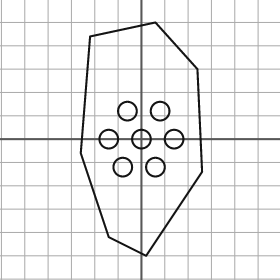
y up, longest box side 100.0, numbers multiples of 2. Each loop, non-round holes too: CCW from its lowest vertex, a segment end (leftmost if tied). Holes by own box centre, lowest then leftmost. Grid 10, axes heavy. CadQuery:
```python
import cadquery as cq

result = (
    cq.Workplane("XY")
    .moveTo(2.0, -50.0)
    .lineTo(26.0, -14.0)
    .lineTo(24.0, 30.0)
    .lineTo(6.0, 50.0)
    .lineTo(-22.0, 44.0)
    .lineTo(-26.0, -6.0)
    .lineTo(-14.0, -42.0)
    .close()
    .moveTo(-8.0, -12.0)
    .circle(4.0)
    .moveTo(6.0, -12.0)
    .circle(4.0)
    .moveTo(-14.0, 0.0)
    .circle(4.0)
    .moveTo(0.0, 0.0)
    .circle(4.0)
    .moveTo(14.0, 0.0)
    .circle(4.0)
    .moveTo(-6.0, 12.0)
    .circle(4.0)
    .moveTo(8.0, 12.0)
    .circle(4.0)
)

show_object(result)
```